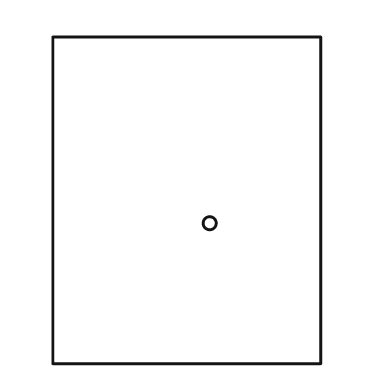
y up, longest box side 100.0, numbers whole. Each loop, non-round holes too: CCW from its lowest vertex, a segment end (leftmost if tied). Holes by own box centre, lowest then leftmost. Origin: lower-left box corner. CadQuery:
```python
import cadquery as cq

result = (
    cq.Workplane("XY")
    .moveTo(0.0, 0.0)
    .lineTo(82.0, 0.0)
    .lineTo(82.0, 100.0)
    .lineTo(0.0, 100.0)
    .close()
    .moveTo(48.0, 43.0)
    .circle(2.0)
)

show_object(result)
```